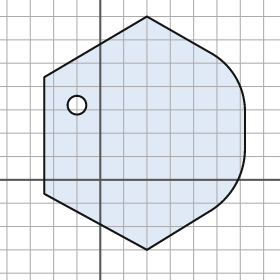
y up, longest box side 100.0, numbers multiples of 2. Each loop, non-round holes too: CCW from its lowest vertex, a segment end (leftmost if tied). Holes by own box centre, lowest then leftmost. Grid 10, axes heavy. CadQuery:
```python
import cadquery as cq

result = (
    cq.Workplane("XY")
    .moveTo(20.0, -30.0)
    .lineTo(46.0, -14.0)
    .threePointArc((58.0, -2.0), (62.0, 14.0))
    .lineTo(62.0, 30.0)
    .threePointArc((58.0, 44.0), (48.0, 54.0))
    .lineTo(20.0, 70.0)
    .lineTo(-24.0, 44.0)
    .lineTo(-24.0, -6.0)
    .close()
    .moveTo(-10.0, 32.0)
    .circle(4.0)
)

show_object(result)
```